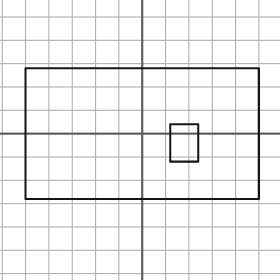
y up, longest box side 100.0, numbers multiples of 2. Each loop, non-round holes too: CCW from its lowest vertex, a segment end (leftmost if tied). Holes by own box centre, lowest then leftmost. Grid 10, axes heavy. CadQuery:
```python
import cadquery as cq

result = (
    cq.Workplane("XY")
    .moveTo(-50.0, -28.0)
    .lineTo(50.0, -28.0)
    .lineTo(50.0, 28.0)
    .lineTo(-50.0, 28.0)
    .close()
    .moveTo(12.0, -12.0)
    .lineTo(24.0, -12.0)
    .lineTo(24.0, 4.0)
    .lineTo(12.0, 4.0)
    .close()
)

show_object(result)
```